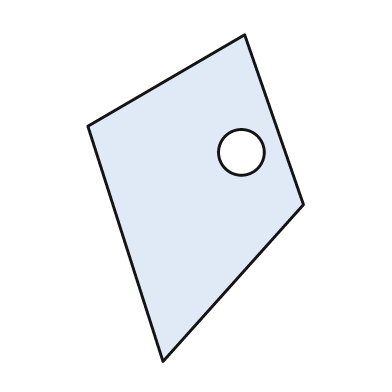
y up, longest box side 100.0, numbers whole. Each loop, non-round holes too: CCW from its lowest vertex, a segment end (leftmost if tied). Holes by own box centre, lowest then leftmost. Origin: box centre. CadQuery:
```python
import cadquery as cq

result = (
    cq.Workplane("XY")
    .moveTo(-10.0, -50.0)
    .lineTo(33.0, -2.0)
    .lineTo(15.0, 50.0)
    .lineTo(-33.0, 22.0)
    .close()
    .moveTo(14.0, 14.0)
    .circle(7.0)
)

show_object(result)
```